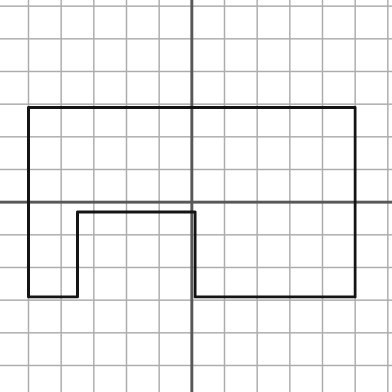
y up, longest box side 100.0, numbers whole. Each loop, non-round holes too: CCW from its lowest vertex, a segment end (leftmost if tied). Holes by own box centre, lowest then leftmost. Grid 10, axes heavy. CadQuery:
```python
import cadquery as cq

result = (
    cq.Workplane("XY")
    .moveTo(-50.0, -29.0)
    .lineTo(-35.0, -29.0)
    .lineTo(-35.0, -3.0)
    .lineTo(1.0, -3.0)
    .lineTo(1.0, -29.0)
    .lineTo(50.0, -29.0)
    .lineTo(50.0, 29.0)
    .lineTo(-50.0, 29.0)
    .close()
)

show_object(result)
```